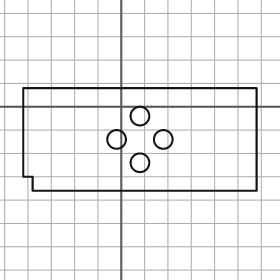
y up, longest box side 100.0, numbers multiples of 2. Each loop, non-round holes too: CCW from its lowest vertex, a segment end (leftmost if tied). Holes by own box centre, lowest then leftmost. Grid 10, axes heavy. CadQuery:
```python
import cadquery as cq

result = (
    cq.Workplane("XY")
    .moveTo(-38.0, -36.0)
    .lineTo(58.0, -36.0)
    .lineTo(58.0, 8.0)
    .lineTo(-42.0, 8.0)
    .lineTo(-42.0, -30.0)
    .lineTo(-38.0, -30.0)
    .close()
    .moveTo(8.0, -24.0)
    .circle(4.0)
    .moveTo(-2.0, -14.0)
    .circle(4.0)
    .moveTo(18.0, -14.0)
    .circle(4.0)
    .moveTo(8.0, -4.0)
    .circle(4.0)
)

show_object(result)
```